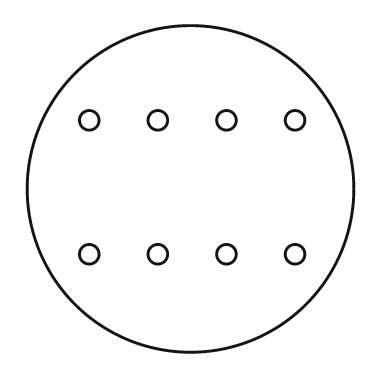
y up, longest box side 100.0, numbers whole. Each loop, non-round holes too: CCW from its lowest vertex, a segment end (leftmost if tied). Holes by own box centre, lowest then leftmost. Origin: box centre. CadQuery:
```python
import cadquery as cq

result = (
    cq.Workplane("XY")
    .moveTo(0.0, 0.0)
    .circle(50.0)
    .moveTo(-31.0, -20.0)
    .circle(3.0)
    .moveTo(-10.0, -20.0)
    .circle(3.0)
    .moveTo(11.0, -20.0)
    .circle(3.0)
    .moveTo(32.0, -20.0)
    .circle(3.0)
    .moveTo(-31.0, 21.0)
    .circle(3.0)
    .moveTo(-10.0, 21.0)
    .circle(3.0)
    .moveTo(11.0, 21.0)
    .circle(3.0)
    .moveTo(32.0, 21.0)
    .circle(3.0)
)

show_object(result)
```